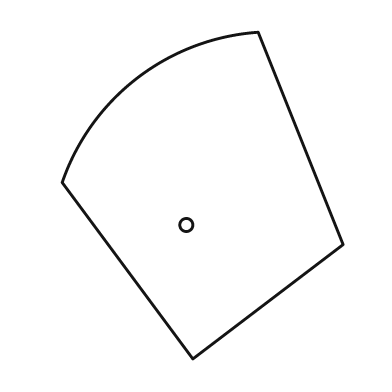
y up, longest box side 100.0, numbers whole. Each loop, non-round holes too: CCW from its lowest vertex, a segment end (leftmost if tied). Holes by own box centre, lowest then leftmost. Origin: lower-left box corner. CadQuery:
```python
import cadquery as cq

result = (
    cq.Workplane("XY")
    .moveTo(40.0, 0.0)
    .lineTo(86.0, 35.0)
    .lineTo(60.0, 100.0)
    .threePointArc((23.0, 86.0), (0.0, 54.0))
    .close()
    .moveTo(38.0, 41.0)
    .circle(2.0)
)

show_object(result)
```